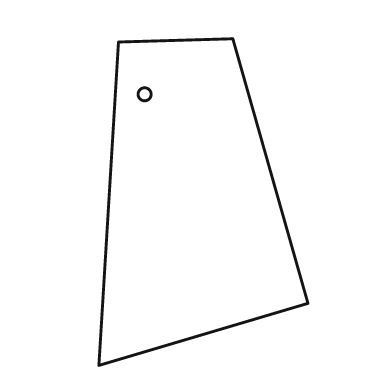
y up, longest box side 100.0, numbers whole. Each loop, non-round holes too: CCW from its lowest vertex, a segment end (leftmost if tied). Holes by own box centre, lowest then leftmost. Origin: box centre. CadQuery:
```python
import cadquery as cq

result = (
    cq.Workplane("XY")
    .moveTo(-32.0, -50.0)
    .lineTo(32.0, -31.0)
    .lineTo(9.0, 50.0)
    .lineTo(-26.0, 49.0)
    .close()
    .moveTo(-18.0, 33.0)
    .circle(2.0)
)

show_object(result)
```